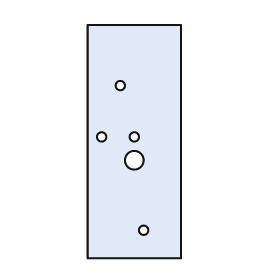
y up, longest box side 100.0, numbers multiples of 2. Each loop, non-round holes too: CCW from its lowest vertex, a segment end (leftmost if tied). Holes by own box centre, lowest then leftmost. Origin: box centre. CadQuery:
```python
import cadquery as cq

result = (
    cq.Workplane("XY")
    .moveTo(-20.0, -50.0)
    .lineTo(20.0, -50.0)
    .lineTo(20.0, 50.0)
    .lineTo(-20.0, 50.0)
    .close()
    .moveTo(4.0, -38.0)
    .circle(2.0)
    .moveTo(0.0, -8.0)
    .circle(4.0)
    .moveTo(-14.0, 2.0)
    .circle(2.0)
    .moveTo(0.0, 2.0)
    .circle(2.0)
    .moveTo(-6.0, 24.0)
    .circle(2.0)
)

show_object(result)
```